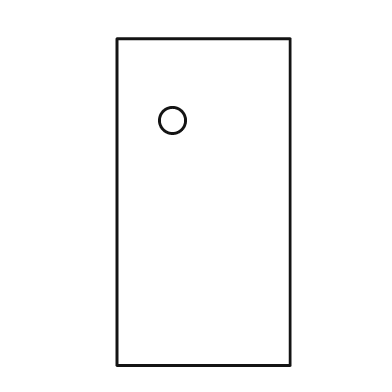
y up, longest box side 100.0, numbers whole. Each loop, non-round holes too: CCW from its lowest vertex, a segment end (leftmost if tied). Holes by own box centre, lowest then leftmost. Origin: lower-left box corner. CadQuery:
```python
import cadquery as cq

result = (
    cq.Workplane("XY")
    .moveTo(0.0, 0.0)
    .lineTo(53.0, 0.0)
    .lineTo(53.0, 100.0)
    .lineTo(0.0, 100.0)
    .close()
    .moveTo(17.0, 75.0)
    .circle(4.0)
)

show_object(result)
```